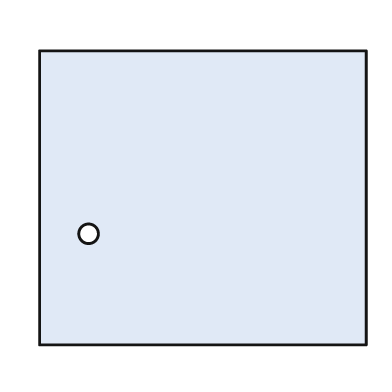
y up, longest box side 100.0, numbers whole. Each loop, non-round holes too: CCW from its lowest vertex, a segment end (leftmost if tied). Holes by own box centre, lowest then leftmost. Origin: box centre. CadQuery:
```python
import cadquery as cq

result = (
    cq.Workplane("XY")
    .moveTo(-50.0, -45.0)
    .lineTo(50.0, -45.0)
    .lineTo(50.0, 45.0)
    .lineTo(-50.0, 45.0)
    .close()
    .moveTo(-35.0, -11.0)
    .circle(3.0)
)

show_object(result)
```